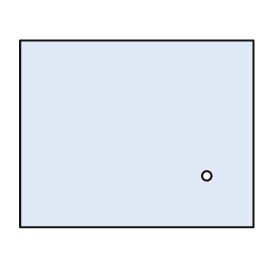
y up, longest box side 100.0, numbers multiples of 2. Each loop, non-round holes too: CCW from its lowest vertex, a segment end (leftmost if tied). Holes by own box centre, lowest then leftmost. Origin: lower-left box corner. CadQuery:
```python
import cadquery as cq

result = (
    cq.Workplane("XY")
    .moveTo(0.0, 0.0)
    .lineTo(100.0, 0.0)
    .lineTo(100.0, 80.0)
    .lineTo(0.0, 80.0)
    .close()
    .moveTo(80.0, 22.0)
    .circle(2.0)
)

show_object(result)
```